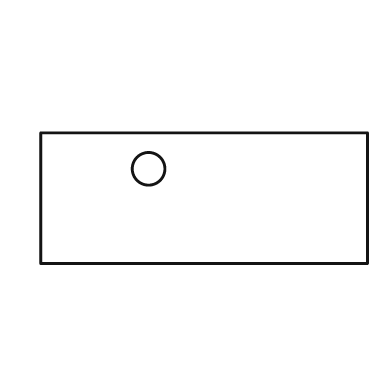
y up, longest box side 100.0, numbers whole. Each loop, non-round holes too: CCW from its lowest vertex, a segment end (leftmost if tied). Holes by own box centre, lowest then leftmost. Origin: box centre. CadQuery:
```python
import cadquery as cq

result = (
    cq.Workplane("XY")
    .moveTo(-50.0, -20.0)
    .lineTo(50.0, -20.0)
    .lineTo(50.0, 20.0)
    .lineTo(-50.0, 20.0)
    .close()
    .moveTo(-17.0, 9.0)
    .circle(5.0)
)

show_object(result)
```